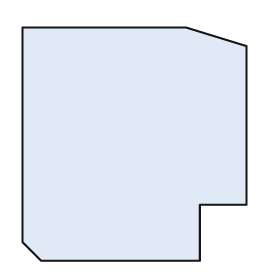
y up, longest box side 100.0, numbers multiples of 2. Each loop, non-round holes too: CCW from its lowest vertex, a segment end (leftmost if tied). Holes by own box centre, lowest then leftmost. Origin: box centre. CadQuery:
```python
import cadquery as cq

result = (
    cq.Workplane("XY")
    .moveTo(-40.0, -50.0)
    .lineTo(28.0, -50.0)
    .lineTo(28.0, -26.0)
    .lineTo(48.0, -26.0)
    .lineTo(48.0, 42.0)
    .lineTo(22.0, 50.0)
    .lineTo(-48.0, 50.0)
    .lineTo(-48.0, -42.0)
    .close()
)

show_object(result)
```